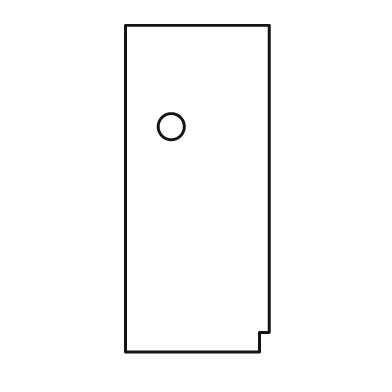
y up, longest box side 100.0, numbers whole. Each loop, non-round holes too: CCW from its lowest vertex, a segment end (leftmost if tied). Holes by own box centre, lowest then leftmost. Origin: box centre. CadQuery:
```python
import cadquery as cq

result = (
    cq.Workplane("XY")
    .moveTo(-22.0, -50.0)
    .lineTo(19.0, -50.0)
    .lineTo(19.0, -44.0)
    .lineTo(22.0, -44.0)
    .lineTo(22.0, 50.0)
    .lineTo(-22.0, 50.0)
    .close()
    .moveTo(-8.0, 19.0)
    .circle(4.0)
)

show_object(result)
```